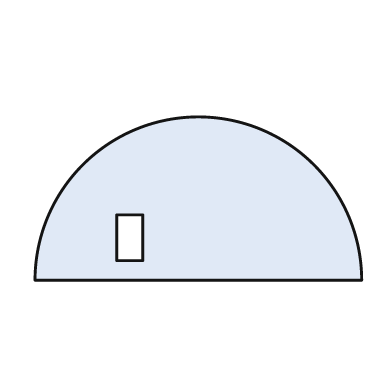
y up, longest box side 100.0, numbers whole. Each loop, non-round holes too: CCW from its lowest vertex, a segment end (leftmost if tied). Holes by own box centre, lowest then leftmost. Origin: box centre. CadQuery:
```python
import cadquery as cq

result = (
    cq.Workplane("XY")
    .moveTo(-50.0, -25.0)
    .lineTo(50.0, -25.0)
    .threePointArc((0.0, 25.0), (-50.0, -25.0))
    .close()
    .moveTo(-25.0, -19.0)
    .lineTo(-17.0, -19.0)
    .lineTo(-17.0, -5.0)
    .lineTo(-25.0, -5.0)
    .close()
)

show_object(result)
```